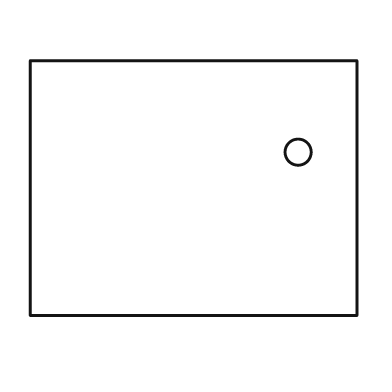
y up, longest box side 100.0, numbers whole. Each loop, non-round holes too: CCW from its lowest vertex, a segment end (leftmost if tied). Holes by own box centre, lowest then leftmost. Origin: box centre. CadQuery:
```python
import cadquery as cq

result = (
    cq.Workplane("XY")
    .moveTo(-50.0, -39.0)
    .lineTo(50.0, -39.0)
    .lineTo(50.0, 39.0)
    .lineTo(-50.0, 39.0)
    .close()
    .moveTo(32.0, 11.0)
    .circle(4.0)
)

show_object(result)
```